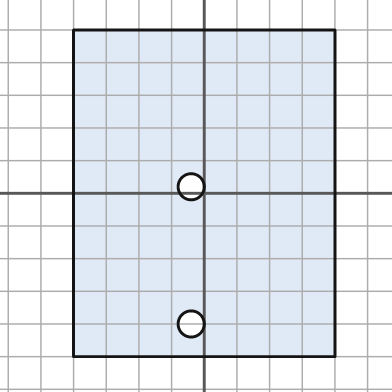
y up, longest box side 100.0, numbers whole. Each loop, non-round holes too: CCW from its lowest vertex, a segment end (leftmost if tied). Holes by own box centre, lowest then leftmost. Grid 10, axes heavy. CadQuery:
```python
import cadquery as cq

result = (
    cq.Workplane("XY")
    .moveTo(-40.0, -50.0)
    .lineTo(40.0, -50.0)
    .lineTo(40.0, 50.0)
    .lineTo(-40.0, 50.0)
    .close()
    .moveTo(-4.0, -40.0)
    .circle(4.0)
    .moveTo(-4.0, 2.0)
    .circle(4.0)
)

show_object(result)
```